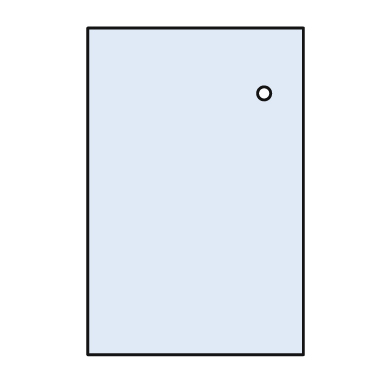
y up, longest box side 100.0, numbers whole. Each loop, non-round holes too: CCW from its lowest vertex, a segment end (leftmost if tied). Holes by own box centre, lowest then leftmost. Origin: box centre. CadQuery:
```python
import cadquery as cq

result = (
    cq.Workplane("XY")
    .moveTo(-33.0, -50.0)
    .lineTo(33.0, -50.0)
    .lineTo(33.0, 50.0)
    .lineTo(-33.0, 50.0)
    .close()
    .moveTo(21.0, 30.0)
    .circle(2.0)
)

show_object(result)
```